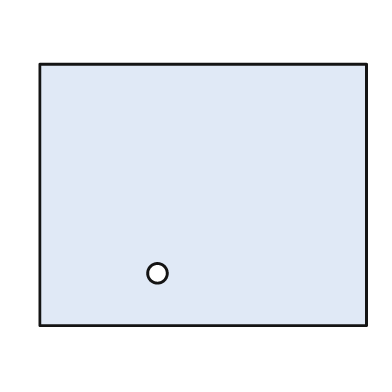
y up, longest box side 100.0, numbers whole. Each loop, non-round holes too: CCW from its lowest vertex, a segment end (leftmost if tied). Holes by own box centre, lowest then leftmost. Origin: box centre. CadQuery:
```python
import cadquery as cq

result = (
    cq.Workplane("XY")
    .moveTo(-50.0, -40.0)
    .lineTo(50.0, -40.0)
    .lineTo(50.0, 40.0)
    .lineTo(-50.0, 40.0)
    .close()
    .moveTo(-14.0, -24.0)
    .circle(3.0)
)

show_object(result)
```